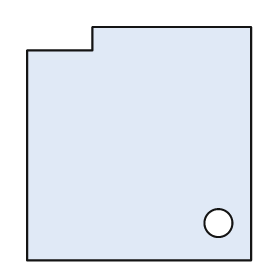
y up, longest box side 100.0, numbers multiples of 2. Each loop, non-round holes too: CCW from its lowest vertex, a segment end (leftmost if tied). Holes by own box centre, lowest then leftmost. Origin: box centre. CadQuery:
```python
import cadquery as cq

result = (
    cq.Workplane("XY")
    .moveTo(-48.0, -50.0)
    .lineTo(48.0, -50.0)
    .lineTo(48.0, 50.0)
    .lineTo(-20.0, 50.0)
    .lineTo(-20.0, 40.0)
    .lineTo(-48.0, 40.0)
    .close()
    .moveTo(34.0, -34.0)
    .circle(6.0)
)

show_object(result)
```